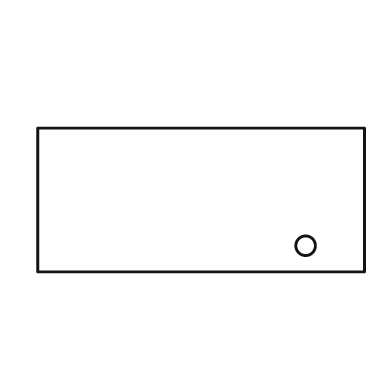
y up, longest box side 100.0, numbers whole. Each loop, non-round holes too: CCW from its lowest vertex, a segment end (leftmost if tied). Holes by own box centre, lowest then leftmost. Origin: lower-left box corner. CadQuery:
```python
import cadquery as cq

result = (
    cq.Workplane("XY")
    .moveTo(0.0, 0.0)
    .lineTo(100.0, 0.0)
    .lineTo(100.0, 44.0)
    .lineTo(0.0, 44.0)
    .close()
    .moveTo(82.0, 8.0)
    .circle(3.0)
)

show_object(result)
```